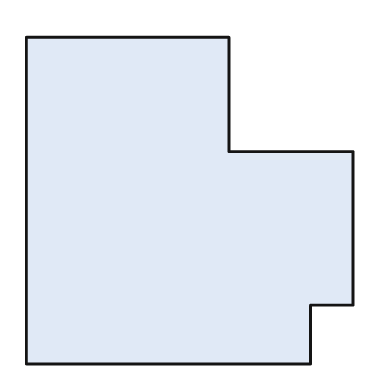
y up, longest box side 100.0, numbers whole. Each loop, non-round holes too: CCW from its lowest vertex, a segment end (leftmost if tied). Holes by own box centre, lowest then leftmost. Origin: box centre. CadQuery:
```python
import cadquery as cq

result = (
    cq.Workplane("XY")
    .moveTo(-50.0, -50.0)
    .lineTo(37.0, -50.0)
    .lineTo(37.0, -32.0)
    .lineTo(50.0, -32.0)
    .lineTo(50.0, 15.0)
    .lineTo(12.0, 15.0)
    .lineTo(12.0, 50.0)
    .lineTo(-50.0, 50.0)
    .close()
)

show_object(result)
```